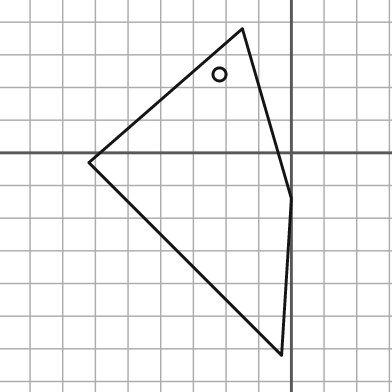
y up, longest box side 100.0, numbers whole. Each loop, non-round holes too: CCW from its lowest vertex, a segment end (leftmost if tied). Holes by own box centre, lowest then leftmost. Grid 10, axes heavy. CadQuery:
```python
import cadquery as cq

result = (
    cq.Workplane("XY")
    .moveTo(-3.0, -62.0)
    .lineTo(0.0, -14.0)
    .lineTo(-15.0, 38.0)
    .lineTo(-62.0, -3.0)
    .close()
    .moveTo(-22.0, 24.0)
    .circle(2.0)
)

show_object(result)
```